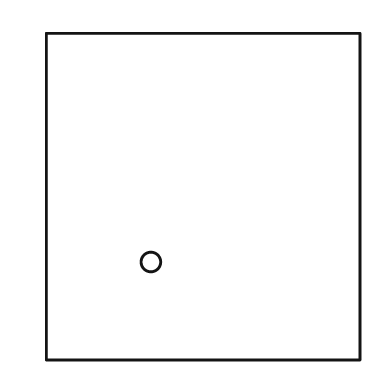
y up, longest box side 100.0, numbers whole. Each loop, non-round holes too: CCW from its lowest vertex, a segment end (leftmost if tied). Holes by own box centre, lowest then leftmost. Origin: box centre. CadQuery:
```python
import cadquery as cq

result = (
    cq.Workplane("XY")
    .moveTo(-48.0, -50.0)
    .lineTo(48.0, -50.0)
    .lineTo(48.0, 50.0)
    .lineTo(-48.0, 50.0)
    .close()
    .moveTo(-16.0, -20.0)
    .circle(3.0)
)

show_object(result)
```